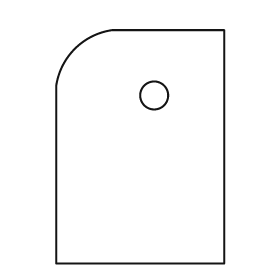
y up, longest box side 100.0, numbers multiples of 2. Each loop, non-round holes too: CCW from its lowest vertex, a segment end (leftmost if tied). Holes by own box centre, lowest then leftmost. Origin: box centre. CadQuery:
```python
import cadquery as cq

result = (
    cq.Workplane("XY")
    .moveTo(-36.0, -50.0)
    .lineTo(36.0, -50.0)
    .lineTo(36.0, 50.0)
    .lineTo(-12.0, 50.0)
    .threePointArc((-28.0, 42.0), (-36.0, 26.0))
    .close()
    .moveTo(6.0, 22.0)
    .circle(6.0)
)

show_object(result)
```